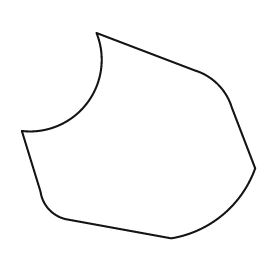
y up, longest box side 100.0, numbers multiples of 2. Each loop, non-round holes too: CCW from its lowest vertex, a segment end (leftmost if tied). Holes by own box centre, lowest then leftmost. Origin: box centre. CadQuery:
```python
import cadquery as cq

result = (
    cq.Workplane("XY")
    .moveTo(14.0, -44.0)
    .threePointArc((36.0, -34.0), (50.0, -14.0))
    .lineTo(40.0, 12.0)
    .threePointArc((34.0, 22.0), (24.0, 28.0))
    .lineTo(-18.0, 44.0)
    .threePointArc((-22.0, 14.0), (-50.0, 2.0))
    .lineTo(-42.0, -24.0)
    .threePointArc((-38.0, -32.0), (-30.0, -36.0))
    .close()
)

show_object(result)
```